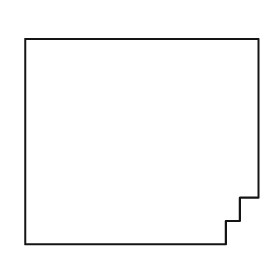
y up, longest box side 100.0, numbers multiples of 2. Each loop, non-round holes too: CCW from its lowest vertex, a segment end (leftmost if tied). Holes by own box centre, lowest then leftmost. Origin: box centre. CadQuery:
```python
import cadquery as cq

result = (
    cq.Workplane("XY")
    .moveTo(-50.0, -44.0)
    .lineTo(36.0, -44.0)
    .lineTo(36.0, -34.0)
    .lineTo(42.0, -34.0)
    .lineTo(42.0, -24.0)
    .lineTo(50.0, -24.0)
    .lineTo(50.0, 44.0)
    .lineTo(-50.0, 44.0)
    .close()
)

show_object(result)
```